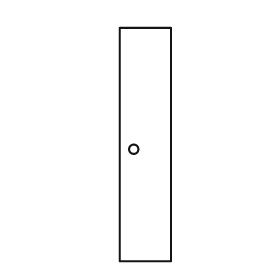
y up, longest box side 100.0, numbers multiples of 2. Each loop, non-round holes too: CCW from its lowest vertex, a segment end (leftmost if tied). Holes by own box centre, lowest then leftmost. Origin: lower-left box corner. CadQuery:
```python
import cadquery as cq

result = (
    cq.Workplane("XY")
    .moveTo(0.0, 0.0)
    .lineTo(22.0, 0.0)
    .lineTo(22.0, 100.0)
    .lineTo(0.0, 100.0)
    .close()
    .moveTo(6.0, 48.0)
    .circle(2.0)
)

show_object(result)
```